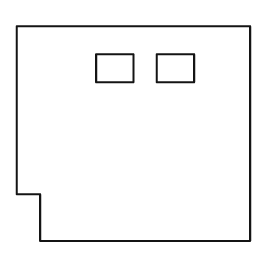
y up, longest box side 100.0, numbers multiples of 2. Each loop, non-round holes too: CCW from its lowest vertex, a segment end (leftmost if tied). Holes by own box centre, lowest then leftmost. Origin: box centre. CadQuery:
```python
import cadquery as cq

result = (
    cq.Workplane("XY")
    .moveTo(-40.0, -46.0)
    .lineTo(50.0, -46.0)
    .lineTo(50.0, 46.0)
    .lineTo(-50.0, 46.0)
    .lineTo(-50.0, -26.0)
    .lineTo(-40.0, -26.0)
    .close()
    .moveTo(-16.0, 22.0)
    .lineTo(0.0, 22.0)
    .lineTo(0.0, 34.0)
    .lineTo(-16.0, 34.0)
    .close()
    .moveTo(10.0, 22.0)
    .lineTo(26.0, 22.0)
    .lineTo(26.0, 34.0)
    .lineTo(10.0, 34.0)
    .close()
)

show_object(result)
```